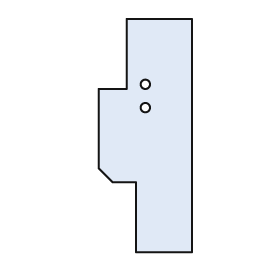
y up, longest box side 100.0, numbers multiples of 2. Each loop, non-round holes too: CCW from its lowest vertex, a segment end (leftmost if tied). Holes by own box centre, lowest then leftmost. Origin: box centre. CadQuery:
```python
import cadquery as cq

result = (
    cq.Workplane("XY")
    .moveTo(-4.0, -50.0)
    .lineTo(20.0, -50.0)
    .lineTo(20.0, 50.0)
    .lineTo(-8.0, 50.0)
    .lineTo(-8.0, 20.0)
    .lineTo(-20.0, 20.0)
    .lineTo(-20.0, -14.0)
    .lineTo(-14.0, -20.0)
    .lineTo(-4.0, -20.0)
    .close()
    .moveTo(0.0, 12.0)
    .circle(2.0)
    .moveTo(0.0, 22.0)
    .circle(2.0)
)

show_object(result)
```